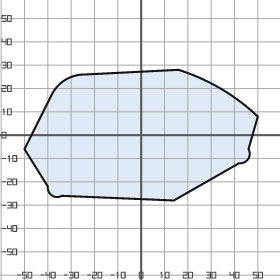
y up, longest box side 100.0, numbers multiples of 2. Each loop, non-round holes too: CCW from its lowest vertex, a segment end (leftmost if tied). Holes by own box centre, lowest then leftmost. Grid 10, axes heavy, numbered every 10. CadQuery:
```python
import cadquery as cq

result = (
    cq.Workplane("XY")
    .moveTo(14.0, -28.0)
    .lineTo(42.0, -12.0)
    .threePointArc((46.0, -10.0), (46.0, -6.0))
    .lineTo(50.0, 8.0)
    .threePointArc((34.0, 20.0), (16.0, 28.0))
    .lineTo(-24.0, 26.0)
    .threePointArc((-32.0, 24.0), (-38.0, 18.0))
    .lineTo(-50.0, -6.0)
    .lineTo(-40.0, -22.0)
    .threePointArc((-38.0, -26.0), (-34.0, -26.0))
    .close()
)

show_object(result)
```